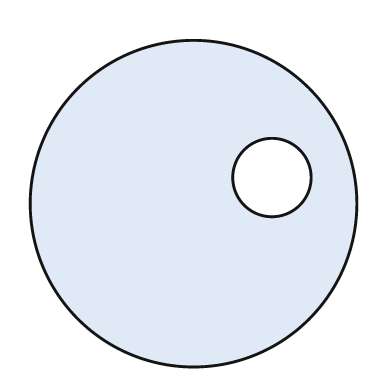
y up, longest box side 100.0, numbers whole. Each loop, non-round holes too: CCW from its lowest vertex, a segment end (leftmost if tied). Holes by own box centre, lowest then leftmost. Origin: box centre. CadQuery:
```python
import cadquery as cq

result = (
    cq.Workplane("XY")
    .moveTo(0.0, 0.0)
    .circle(50.0)
    .moveTo(24.0, 8.0)
    .circle(12.0)
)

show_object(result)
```